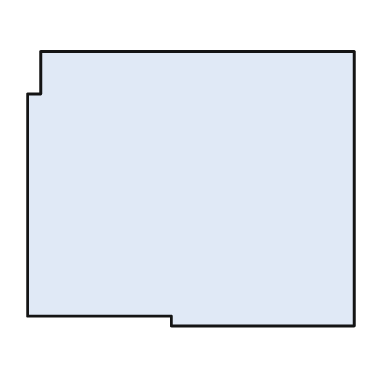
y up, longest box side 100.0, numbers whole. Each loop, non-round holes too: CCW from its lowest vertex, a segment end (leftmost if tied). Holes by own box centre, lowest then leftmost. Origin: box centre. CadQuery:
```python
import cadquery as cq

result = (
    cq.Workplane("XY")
    .moveTo(-6.0, -42.0)
    .lineTo(50.0, -42.0)
    .lineTo(50.0, 42.0)
    .lineTo(-46.0, 42.0)
    .lineTo(-46.0, 29.0)
    .lineTo(-50.0, 29.0)
    .lineTo(-50.0, -39.0)
    .lineTo(-6.0, -39.0)
    .close()
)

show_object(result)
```